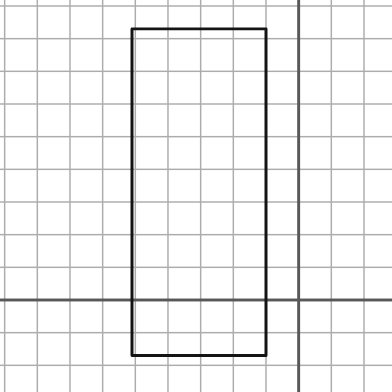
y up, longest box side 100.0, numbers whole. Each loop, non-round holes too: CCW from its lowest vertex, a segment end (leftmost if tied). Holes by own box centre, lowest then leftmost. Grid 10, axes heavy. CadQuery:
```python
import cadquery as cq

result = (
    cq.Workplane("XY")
    .moveTo(-51.0, -17.0)
    .lineTo(-10.0, -17.0)
    .lineTo(-10.0, 83.0)
    .lineTo(-51.0, 83.0)
    .close()
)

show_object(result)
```